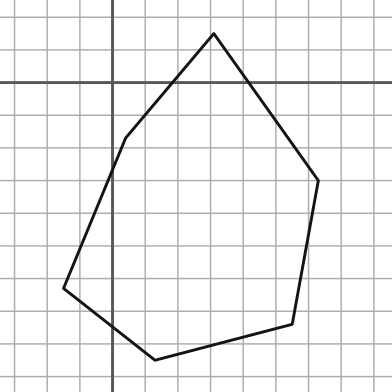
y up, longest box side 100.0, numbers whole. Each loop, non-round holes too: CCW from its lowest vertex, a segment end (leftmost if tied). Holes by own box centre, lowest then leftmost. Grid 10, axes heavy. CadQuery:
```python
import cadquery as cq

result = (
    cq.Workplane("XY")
    .moveTo(13.0, -85.0)
    .lineTo(55.0, -74.0)
    .lineTo(63.0, -30.0)
    .lineTo(31.0, 15.0)
    .lineTo(4.0, -17.0)
    .lineTo(-15.0, -63.0)
    .close()
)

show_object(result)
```